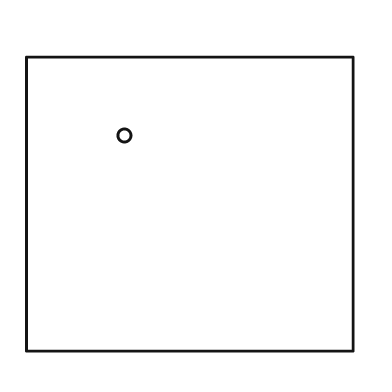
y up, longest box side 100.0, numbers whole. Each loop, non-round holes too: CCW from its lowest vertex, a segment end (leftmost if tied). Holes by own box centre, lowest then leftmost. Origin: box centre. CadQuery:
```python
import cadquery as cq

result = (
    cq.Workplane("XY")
    .moveTo(-50.0, -45.0)
    .lineTo(50.0, -45.0)
    .lineTo(50.0, 45.0)
    .lineTo(-50.0, 45.0)
    .close()
    .moveTo(-20.0, 21.0)
    .circle(2.0)
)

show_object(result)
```